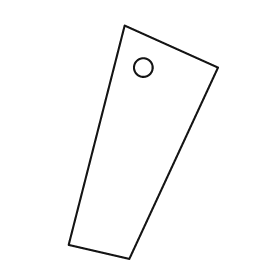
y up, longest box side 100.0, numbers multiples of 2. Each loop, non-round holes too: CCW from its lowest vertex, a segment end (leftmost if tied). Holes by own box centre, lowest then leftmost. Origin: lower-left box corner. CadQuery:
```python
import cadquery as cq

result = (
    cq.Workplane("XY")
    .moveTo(26.0, 0.0)
    .lineTo(64.0, 82.0)
    .lineTo(24.0, 100.0)
    .lineTo(0.0, 6.0)
    .close()
    .moveTo(32.0, 82.0)
    .circle(4.0)
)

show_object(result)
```